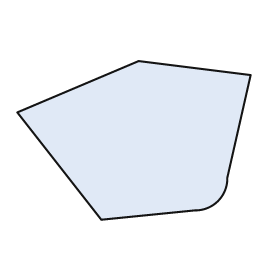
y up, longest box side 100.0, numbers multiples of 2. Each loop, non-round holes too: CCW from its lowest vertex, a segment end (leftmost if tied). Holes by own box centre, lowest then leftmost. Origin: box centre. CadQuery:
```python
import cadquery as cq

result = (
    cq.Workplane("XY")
    .moveTo(-14.0, -34.0)
    .lineTo(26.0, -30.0)
    .threePointArc((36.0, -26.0), (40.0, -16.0))
    .lineTo(50.0, 28.0)
    .lineTo(2.0, 34.0)
    .lineTo(-50.0, 12.0)
    .close()
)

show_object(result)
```